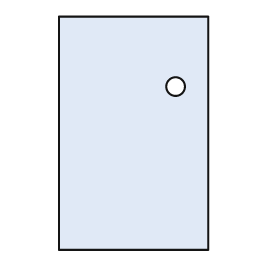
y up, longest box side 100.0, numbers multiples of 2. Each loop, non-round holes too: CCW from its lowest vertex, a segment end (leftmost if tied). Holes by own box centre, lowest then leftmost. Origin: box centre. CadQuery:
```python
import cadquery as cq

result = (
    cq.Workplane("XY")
    .moveTo(-32.0, -50.0)
    .lineTo(32.0, -50.0)
    .lineTo(32.0, 50.0)
    .lineTo(-32.0, 50.0)
    .close()
    .moveTo(18.0, 20.0)
    .circle(4.0)
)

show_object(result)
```